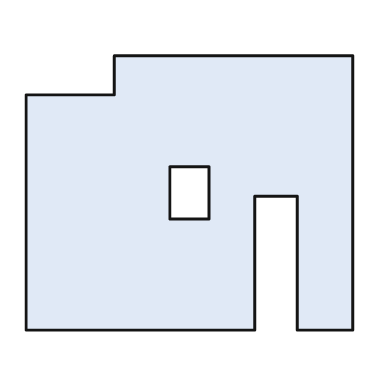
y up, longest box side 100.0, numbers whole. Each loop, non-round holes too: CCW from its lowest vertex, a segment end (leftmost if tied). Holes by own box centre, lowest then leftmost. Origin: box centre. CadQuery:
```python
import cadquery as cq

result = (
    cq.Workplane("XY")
    .moveTo(-50.0, -42.0)
    .lineTo(20.0, -42.0)
    .lineTo(20.0, -1.0)
    .lineTo(33.0, -1.0)
    .lineTo(33.0, -42.0)
    .lineTo(50.0, -42.0)
    .lineTo(50.0, 42.0)
    .lineTo(-23.0, 42.0)
    .lineTo(-23.0, 30.0)
    .lineTo(-50.0, 30.0)
    .close()
    .moveTo(-6.0, -8.0)
    .lineTo(6.0, -8.0)
    .lineTo(6.0, 8.0)
    .lineTo(-6.0, 8.0)
    .close()
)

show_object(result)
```